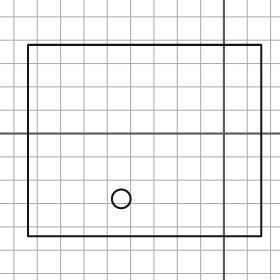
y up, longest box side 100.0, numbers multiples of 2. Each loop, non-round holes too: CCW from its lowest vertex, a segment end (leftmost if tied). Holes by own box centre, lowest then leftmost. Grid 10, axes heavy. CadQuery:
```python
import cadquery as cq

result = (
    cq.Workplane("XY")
    .moveTo(-84.0, -44.0)
    .lineTo(16.0, -44.0)
    .lineTo(16.0, 38.0)
    .lineTo(-84.0, 38.0)
    .close()
    .moveTo(-44.0, -28.0)
    .circle(4.0)
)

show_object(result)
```